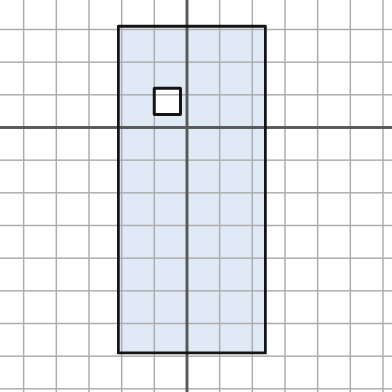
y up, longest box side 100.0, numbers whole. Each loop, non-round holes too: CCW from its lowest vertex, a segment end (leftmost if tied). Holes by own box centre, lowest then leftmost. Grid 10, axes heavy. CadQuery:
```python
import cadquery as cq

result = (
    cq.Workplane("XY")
    .moveTo(-21.0, -69.0)
    .lineTo(24.0, -69.0)
    .lineTo(24.0, 31.0)
    .lineTo(-21.0, 31.0)
    .close()
    .moveTo(-10.0, 4.0)
    .lineTo(-2.0, 4.0)
    .lineTo(-2.0, 12.0)
    .lineTo(-10.0, 12.0)
    .close()
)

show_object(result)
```